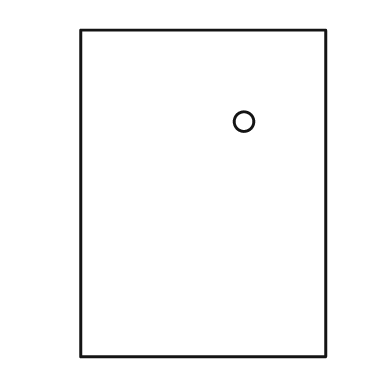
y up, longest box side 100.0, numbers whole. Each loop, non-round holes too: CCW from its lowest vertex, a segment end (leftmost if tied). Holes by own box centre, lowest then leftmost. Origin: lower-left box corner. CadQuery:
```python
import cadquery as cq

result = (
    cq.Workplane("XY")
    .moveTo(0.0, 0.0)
    .lineTo(75.0, 0.0)
    .lineTo(75.0, 100.0)
    .lineTo(0.0, 100.0)
    .close()
    .moveTo(50.0, 72.0)
    .circle(3.0)
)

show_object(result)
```